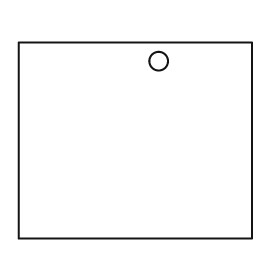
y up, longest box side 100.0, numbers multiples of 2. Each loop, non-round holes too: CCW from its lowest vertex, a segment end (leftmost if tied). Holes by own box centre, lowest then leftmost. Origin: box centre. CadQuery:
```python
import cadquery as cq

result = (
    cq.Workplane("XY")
    .moveTo(-50.0, -42.0)
    .lineTo(50.0, -42.0)
    .lineTo(50.0, 42.0)
    .lineTo(-50.0, 42.0)
    .close()
    .moveTo(10.0, 34.0)
    .circle(4.0)
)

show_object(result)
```